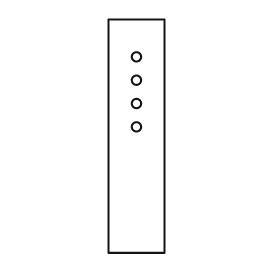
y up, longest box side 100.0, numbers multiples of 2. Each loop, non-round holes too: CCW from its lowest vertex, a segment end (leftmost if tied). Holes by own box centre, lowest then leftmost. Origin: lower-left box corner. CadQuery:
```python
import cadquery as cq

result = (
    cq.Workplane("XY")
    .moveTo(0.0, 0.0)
    .lineTo(24.0, 0.0)
    .lineTo(24.0, 100.0)
    .lineTo(0.0, 100.0)
    .close()
    .moveTo(12.0, 54.0)
    .circle(2.0)
    .moveTo(12.0, 64.0)
    .circle(2.0)
    .moveTo(12.0, 74.0)
    .circle(2.0)
    .moveTo(12.0, 84.0)
    .circle(2.0)
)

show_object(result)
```